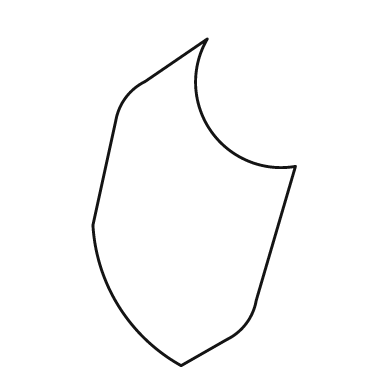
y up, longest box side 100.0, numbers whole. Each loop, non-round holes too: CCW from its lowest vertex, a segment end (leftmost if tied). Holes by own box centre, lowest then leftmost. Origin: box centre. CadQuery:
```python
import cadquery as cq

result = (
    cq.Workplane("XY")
    .moveTo(-4.0, -50.0)
    .lineTo(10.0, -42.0)
    .threePointArc((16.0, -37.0), (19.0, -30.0))
    .lineTo(31.0, 11.0)
    .threePointArc((5.0, 22.0), (4.0, 50.0))
    .lineTo(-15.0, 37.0)
    .threePointArc((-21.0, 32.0), (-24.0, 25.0))
    .lineTo(-31.0, -7.0)
    .threePointArc((-23.0, -32.0), (-4.0, -50.0))
    .close()
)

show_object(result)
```